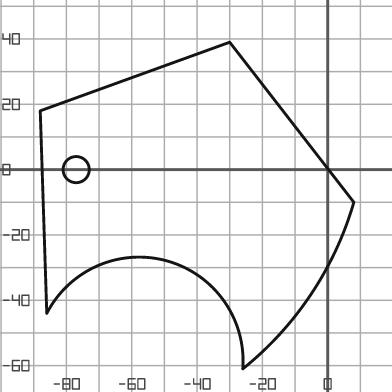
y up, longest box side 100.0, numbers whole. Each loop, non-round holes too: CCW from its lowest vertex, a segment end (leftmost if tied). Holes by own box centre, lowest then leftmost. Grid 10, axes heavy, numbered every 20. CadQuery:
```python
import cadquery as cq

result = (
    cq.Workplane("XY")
    .moveTo(-26.0, -61.0)
    .threePointArc((-5.0, -38.0), (8.0, -10.0))
    .lineTo(-30.0, 39.0)
    .lineTo(-88.0, 18.0)
    .lineTo(-86.0, -44.0)
    .threePointArc((-49.0, -28.0), (-26.0, -61.0))
    .close()
    .moveTo(-77.0, 0.0)
    .circle(4.0)
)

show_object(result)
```